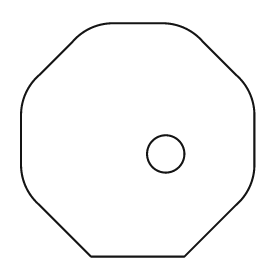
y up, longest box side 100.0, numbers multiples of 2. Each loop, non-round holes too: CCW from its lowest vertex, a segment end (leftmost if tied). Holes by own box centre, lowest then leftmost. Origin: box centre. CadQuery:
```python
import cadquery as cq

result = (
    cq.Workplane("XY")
    .moveTo(-20.0, -50.0)
    .lineTo(20.0, -50.0)
    .lineTo(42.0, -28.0)
    .threePointArc((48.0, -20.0), (50.0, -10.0))
    .lineTo(50.0, 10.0)
    .threePointArc((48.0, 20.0), (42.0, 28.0))
    .lineTo(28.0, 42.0)
    .threePointArc((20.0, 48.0), (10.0, 50.0))
    .lineTo(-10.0, 50.0)
    .threePointArc((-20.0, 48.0), (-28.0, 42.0))
    .lineTo(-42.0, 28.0)
    .threePointArc((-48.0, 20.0), (-50.0, 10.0))
    .lineTo(-50.0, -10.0)
    .threePointArc((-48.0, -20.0), (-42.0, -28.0))
    .close()
    .moveTo(12.0, -6.0)
    .circle(8.0)
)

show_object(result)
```